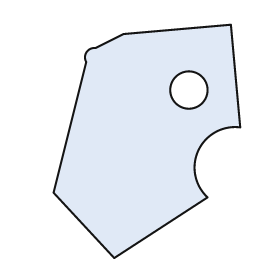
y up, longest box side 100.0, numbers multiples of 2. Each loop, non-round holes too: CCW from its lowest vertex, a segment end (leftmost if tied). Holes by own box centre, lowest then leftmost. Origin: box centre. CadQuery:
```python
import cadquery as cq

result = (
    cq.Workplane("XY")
    .moveTo(-14.0, -50.0)
    .lineTo(26.0, -24.0)
    .threePointArc((22.0, -4.0), (40.0, 6.0))
    .lineTo(36.0, 50.0)
    .lineTo(-10.0, 46.0)
    .lineTo(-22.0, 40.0)
    .threePointArc((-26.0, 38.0), (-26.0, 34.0))
    .lineTo(-40.0, -22.0)
    .close()
    .moveTo(18.0, 22.0)
    .circle(8.0)
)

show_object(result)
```